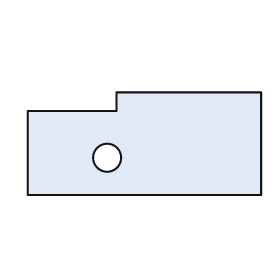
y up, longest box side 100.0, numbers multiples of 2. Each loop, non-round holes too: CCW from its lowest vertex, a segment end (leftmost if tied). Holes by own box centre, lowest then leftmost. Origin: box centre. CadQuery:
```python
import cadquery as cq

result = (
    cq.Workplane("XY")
    .moveTo(-50.0, -22.0)
    .lineTo(50.0, -22.0)
    .lineTo(50.0, 22.0)
    .lineTo(-12.0, 22.0)
    .lineTo(-12.0, 14.0)
    .lineTo(-50.0, 14.0)
    .close()
    .moveTo(-16.0, -6.0)
    .circle(6.0)
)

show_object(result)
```